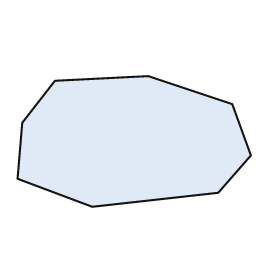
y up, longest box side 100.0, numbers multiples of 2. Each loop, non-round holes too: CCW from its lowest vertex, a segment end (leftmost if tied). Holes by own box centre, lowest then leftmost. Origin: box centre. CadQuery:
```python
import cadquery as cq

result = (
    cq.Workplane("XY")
    .moveTo(-18.0, -28.0)
    .lineTo(36.0, -22.0)
    .lineTo(50.0, -6.0)
    .lineTo(42.0, 16.0)
    .lineTo(6.0, 28.0)
    .lineTo(-34.0, 26.0)
    .lineTo(-48.0, 8.0)
    .lineTo(-50.0, -16.0)
    .close()
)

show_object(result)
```